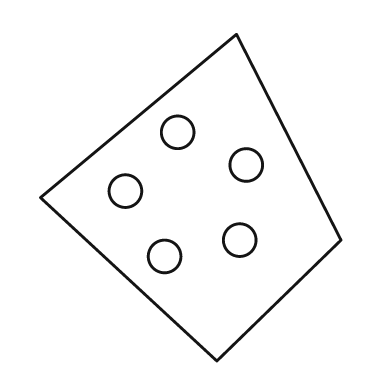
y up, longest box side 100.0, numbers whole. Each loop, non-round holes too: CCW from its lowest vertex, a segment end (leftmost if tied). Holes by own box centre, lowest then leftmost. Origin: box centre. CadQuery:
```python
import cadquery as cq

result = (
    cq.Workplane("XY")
    .moveTo(8.0, -50.0)
    .lineTo(46.0, -13.0)
    .lineTo(14.0, 50.0)
    .lineTo(-46.0, 0.0)
    .close()
    .moveTo(-8.0, -18.0)
    .circle(5.0)
    .moveTo(15.0, -13.0)
    .circle(5.0)
    .moveTo(-20.0, 2.0)
    .circle(5.0)
    .moveTo(17.0, 10.0)
    .circle(5.0)
    .moveTo(-4.0, 20.0)
    .circle(5.0)
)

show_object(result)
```